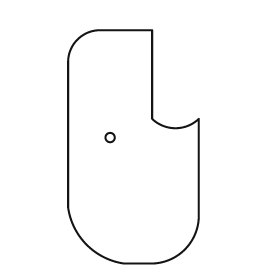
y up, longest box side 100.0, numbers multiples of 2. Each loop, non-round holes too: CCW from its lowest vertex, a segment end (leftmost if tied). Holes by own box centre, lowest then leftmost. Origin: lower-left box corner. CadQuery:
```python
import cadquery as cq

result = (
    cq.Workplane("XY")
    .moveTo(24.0, 0.0)
    .lineTo(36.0, 0.0)
    .threePointArc((50.0, 6.0), (56.0, 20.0))
    .lineTo(56.0, 62.0)
    .threePointArc((46.0, 58.0), (36.0, 62.0))
    .lineTo(36.0, 100.0)
    .lineTo(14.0, 100.0)
    .threePointArc((4.0, 96.0), (0.0, 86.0))
    .lineTo(0.0, 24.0)
    .threePointArc((8.0, 8.0), (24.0, 0.0))
    .close()
    .moveTo(18.0, 54.0)
    .circle(2.0)
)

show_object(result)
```